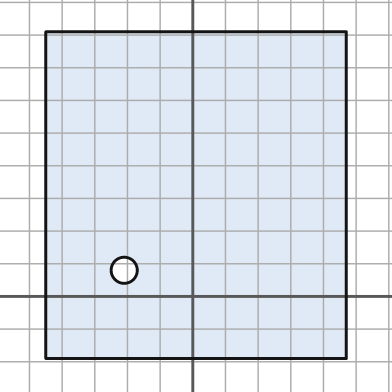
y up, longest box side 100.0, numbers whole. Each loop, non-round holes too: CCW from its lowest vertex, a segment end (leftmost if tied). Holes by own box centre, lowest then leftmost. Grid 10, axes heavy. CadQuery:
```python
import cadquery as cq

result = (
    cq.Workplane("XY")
    .moveTo(-45.0, -19.0)
    .lineTo(47.0, -19.0)
    .lineTo(47.0, 81.0)
    .lineTo(-45.0, 81.0)
    .close()
    .moveTo(-21.0, 8.0)
    .circle(4.0)
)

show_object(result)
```